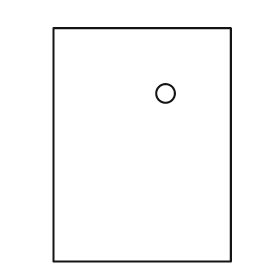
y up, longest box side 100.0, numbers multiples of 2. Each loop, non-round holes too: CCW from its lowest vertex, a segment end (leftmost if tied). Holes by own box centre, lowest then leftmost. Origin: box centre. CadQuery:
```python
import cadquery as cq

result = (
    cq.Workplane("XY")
    .moveTo(-38.0, -50.0)
    .lineTo(38.0, -50.0)
    .lineTo(38.0, 50.0)
    .lineTo(-38.0, 50.0)
    .close()
    .moveTo(10.0, 22.0)
    .circle(4.0)
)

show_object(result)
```